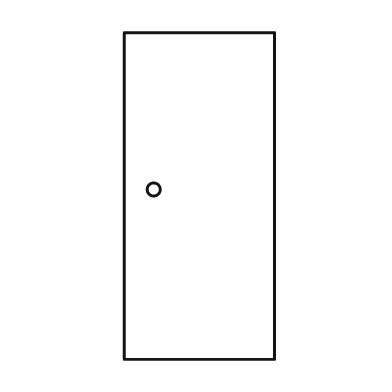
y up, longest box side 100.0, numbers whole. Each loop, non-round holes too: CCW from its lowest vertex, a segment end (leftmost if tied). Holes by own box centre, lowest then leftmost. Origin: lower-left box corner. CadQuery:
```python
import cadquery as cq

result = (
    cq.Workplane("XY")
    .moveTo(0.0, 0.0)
    .lineTo(46.0, 0.0)
    .lineTo(46.0, 100.0)
    .lineTo(0.0, 100.0)
    .close()
    .moveTo(9.0, 52.0)
    .circle(2.0)
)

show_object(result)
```